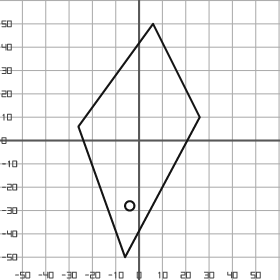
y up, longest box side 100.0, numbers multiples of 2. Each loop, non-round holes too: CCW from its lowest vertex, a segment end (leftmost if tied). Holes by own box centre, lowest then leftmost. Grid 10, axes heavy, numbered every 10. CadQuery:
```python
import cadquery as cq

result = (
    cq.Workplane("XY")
    .moveTo(-6.0, -50.0)
    .lineTo(26.0, 10.0)
    .lineTo(6.0, 50.0)
    .lineTo(-26.0, 6.0)
    .close()
    .moveTo(-4.0, -28.0)
    .circle(2.0)
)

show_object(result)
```